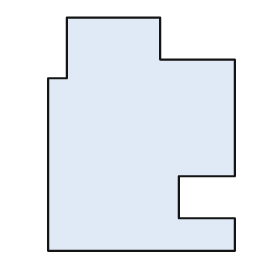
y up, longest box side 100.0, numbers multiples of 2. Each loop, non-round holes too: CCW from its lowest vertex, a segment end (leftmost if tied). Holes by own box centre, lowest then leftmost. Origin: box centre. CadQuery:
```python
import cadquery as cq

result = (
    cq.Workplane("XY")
    .moveTo(-40.0, -50.0)
    .lineTo(40.0, -50.0)
    .lineTo(40.0, -36.0)
    .lineTo(16.0, -36.0)
    .lineTo(16.0, -18.0)
    .lineTo(40.0, -18.0)
    .lineTo(40.0, 32.0)
    .lineTo(8.0, 32.0)
    .lineTo(8.0, 50.0)
    .lineTo(-32.0, 50.0)
    .lineTo(-32.0, 24.0)
    .lineTo(-40.0, 24.0)
    .close()
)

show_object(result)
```